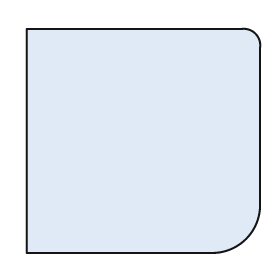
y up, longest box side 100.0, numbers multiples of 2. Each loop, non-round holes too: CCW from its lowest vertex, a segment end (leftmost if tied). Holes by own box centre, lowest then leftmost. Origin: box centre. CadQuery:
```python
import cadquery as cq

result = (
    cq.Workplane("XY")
    .moveTo(-50.0, -48.0)
    .lineTo(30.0, -48.0)
    .threePointArc((44.0, -42.0), (50.0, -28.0))
    .lineTo(50.0, 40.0)
    .threePointArc((48.0, 46.0), (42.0, 48.0))
    .lineTo(-50.0, 48.0)
    .close()
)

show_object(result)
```